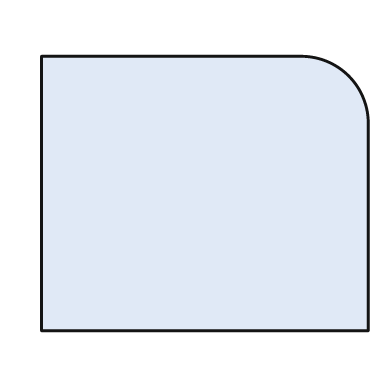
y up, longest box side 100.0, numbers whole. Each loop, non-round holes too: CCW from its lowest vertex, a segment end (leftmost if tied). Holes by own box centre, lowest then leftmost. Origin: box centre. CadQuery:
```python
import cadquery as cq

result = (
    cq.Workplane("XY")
    .moveTo(-50.0, -42.0)
    .lineTo(50.0, -42.0)
    .lineTo(50.0, 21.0)
    .threePointArc((44.0, 36.0), (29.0, 42.0))
    .lineTo(-50.0, 42.0)
    .close()
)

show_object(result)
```